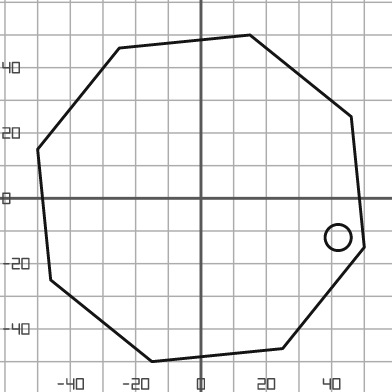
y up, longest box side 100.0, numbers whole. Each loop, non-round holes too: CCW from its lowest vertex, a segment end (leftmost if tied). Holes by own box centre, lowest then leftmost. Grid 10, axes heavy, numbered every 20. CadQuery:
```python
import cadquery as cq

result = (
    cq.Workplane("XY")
    .moveTo(-15.0, -50.0)
    .lineTo(25.0, -46.0)
    .lineTo(50.0, -15.0)
    .lineTo(46.0, 25.0)
    .lineTo(15.0, 50.0)
    .lineTo(-25.0, 46.0)
    .lineTo(-50.0, 15.0)
    .lineTo(-46.0, -25.0)
    .close()
    .moveTo(42.0, -12.0)
    .circle(4.0)
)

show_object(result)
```